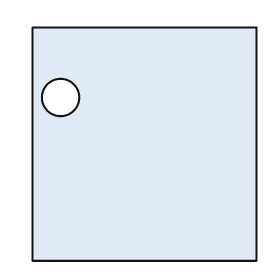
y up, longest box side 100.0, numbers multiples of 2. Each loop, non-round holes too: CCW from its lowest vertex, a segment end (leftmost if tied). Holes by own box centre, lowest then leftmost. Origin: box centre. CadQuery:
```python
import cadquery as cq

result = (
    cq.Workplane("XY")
    .moveTo(-48.0, -50.0)
    .lineTo(48.0, -50.0)
    .lineTo(48.0, 50.0)
    .lineTo(-48.0, 50.0)
    .close()
    .moveTo(-36.0, 20.0)
    .circle(8.0)
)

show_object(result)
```